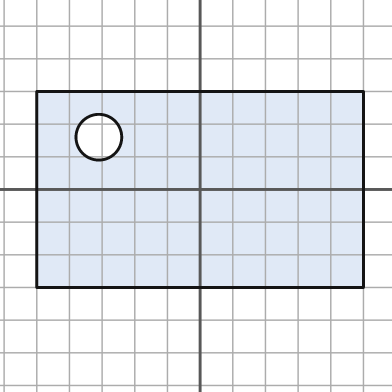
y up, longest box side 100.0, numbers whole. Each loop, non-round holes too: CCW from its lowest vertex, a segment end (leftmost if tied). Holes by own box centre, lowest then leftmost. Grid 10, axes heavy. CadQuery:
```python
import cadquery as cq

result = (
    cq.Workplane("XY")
    .moveTo(-50.0, -30.0)
    .lineTo(50.0, -30.0)
    .lineTo(50.0, 30.0)
    .lineTo(-50.0, 30.0)
    .close()
    .moveTo(-31.0, 16.0)
    .circle(7.0)
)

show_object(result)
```